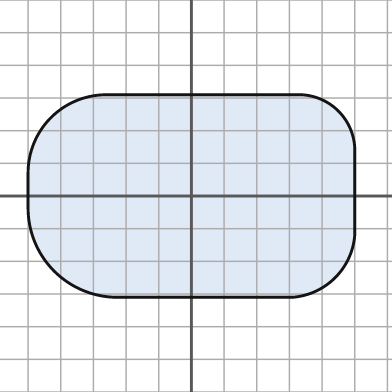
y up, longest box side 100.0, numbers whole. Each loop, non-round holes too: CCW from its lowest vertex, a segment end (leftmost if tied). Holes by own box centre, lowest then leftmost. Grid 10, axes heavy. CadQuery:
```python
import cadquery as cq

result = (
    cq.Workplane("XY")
    .moveTo(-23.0, -31.0)
    .lineTo(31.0, -31.0)
    .threePointArc((44.0, -25.0), (50.0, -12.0))
    .lineTo(50.0, 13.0)
    .threePointArc((45.0, 26.0), (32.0, 31.0))
    .lineTo(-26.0, 31.0)
    .threePointArc((-43.0, 24.0), (-50.0, 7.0))
    .lineTo(-50.0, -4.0)
    .threePointArc((-42.0, -23.0), (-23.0, -31.0))
    .close()
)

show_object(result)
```